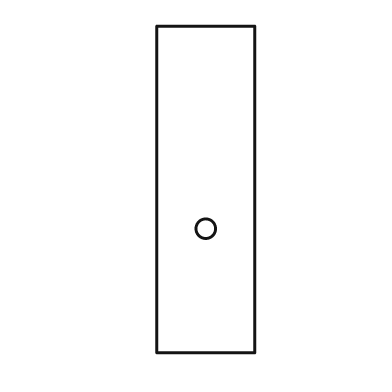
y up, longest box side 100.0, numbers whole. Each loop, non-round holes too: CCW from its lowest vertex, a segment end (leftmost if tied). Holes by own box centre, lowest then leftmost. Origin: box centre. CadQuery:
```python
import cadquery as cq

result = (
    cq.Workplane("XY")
    .moveTo(-15.0, -50.0)
    .lineTo(15.0, -50.0)
    .lineTo(15.0, 50.0)
    .lineTo(-15.0, 50.0)
    .close()
    .moveTo(0.0, -12.0)
    .circle(3.0)
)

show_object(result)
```